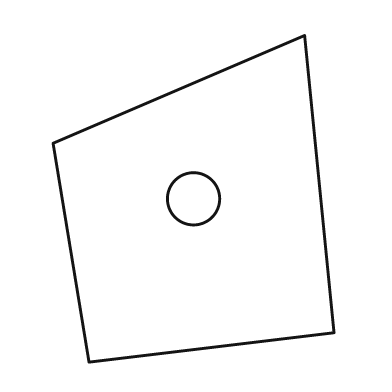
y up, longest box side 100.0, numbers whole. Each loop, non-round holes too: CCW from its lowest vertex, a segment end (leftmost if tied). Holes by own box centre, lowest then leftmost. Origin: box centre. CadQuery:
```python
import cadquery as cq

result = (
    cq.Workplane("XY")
    .moveTo(-32.0, -50.0)
    .lineTo(43.0, -41.0)
    .lineTo(34.0, 50.0)
    .lineTo(-43.0, 17.0)
    .close()
    .moveTo(0.0, 0.0)
    .circle(8.0)
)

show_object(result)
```